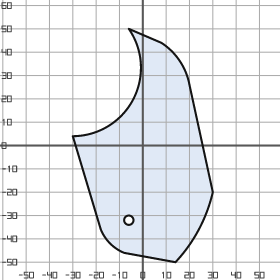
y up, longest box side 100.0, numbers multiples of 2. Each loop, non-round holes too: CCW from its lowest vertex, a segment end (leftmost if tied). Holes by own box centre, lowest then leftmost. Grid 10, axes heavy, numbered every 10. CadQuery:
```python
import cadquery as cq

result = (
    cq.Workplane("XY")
    .moveTo(14.0, -50.0)
    .threePointArc((24.0, -36.0), (30.0, -20.0))
    .lineTo(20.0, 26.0)
    .threePointArc((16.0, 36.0), (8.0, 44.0))
    .lineTo(-6.0, 50.0)
    .threePointArc((-4.0, 20.0), (-30.0, 4.0))
    .lineTo(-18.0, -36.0)
    .threePointArc((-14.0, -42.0), (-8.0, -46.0))
    .close()
    .moveTo(-6.0, -32.0)
    .circle(2.0)
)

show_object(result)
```